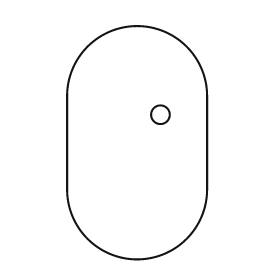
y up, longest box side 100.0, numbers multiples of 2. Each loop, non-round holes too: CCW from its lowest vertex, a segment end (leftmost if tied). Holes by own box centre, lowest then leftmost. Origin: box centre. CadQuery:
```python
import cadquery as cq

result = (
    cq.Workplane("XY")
    .moveTo(-30.0, -20.0)
    .threePointArc((0.0, -50.0), (30.0, -20.0))
    .lineTo(30.0, 20.0)
    .threePointArc((0.0, 50.0), (-30.0, 20.0))
    .close()
    .moveTo(10.0, 12.0)
    .circle(4.0)
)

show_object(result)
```